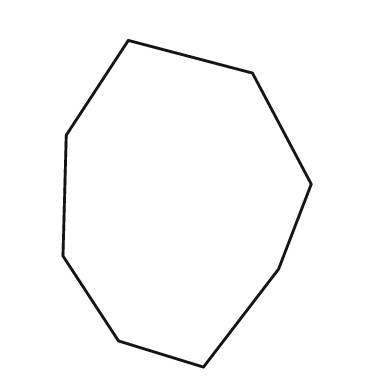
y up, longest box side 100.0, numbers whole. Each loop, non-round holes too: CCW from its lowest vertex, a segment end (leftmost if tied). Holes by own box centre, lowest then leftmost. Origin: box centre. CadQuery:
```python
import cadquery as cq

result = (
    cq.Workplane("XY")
    .moveTo(5.0, -50.0)
    .lineTo(28.0, -20.0)
    .lineTo(38.0, 6.0)
    .lineTo(20.0, 40.0)
    .lineTo(-18.0, 50.0)
    .lineTo(-37.0, 21.0)
    .lineTo(-38.0, -16.0)
    .lineTo(-21.0, -42.0)
    .close()
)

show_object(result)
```